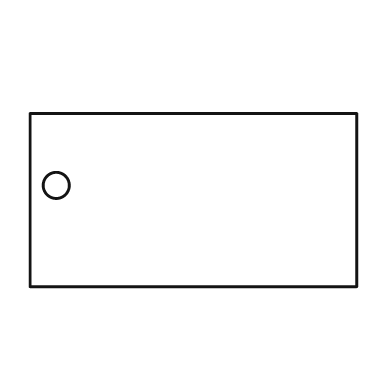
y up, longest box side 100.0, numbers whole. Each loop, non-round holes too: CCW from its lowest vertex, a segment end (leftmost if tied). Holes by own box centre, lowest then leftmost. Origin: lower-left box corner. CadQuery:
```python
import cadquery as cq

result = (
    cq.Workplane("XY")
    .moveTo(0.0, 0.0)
    .lineTo(100.0, 0.0)
    .lineTo(100.0, 53.0)
    .lineTo(0.0, 53.0)
    .close()
    .moveTo(8.0, 31.0)
    .circle(4.0)
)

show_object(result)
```